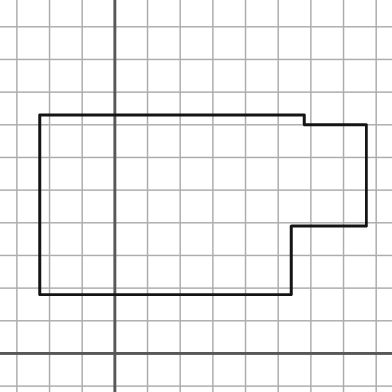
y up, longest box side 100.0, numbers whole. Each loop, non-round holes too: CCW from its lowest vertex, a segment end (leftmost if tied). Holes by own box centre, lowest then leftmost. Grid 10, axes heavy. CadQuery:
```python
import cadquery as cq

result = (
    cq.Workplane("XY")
    .moveTo(-23.0, 18.0)
    .lineTo(54.0, 18.0)
    .lineTo(54.0, 39.0)
    .lineTo(77.0, 39.0)
    .lineTo(77.0, 70.0)
    .lineTo(58.0, 70.0)
    .lineTo(58.0, 73.0)
    .lineTo(-23.0, 73.0)
    .close()
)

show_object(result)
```